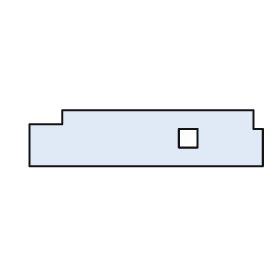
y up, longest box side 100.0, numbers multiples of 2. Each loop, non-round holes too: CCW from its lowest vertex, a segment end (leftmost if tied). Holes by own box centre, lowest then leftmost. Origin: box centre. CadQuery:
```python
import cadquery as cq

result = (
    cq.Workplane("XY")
    .moveTo(-50.0, -12.0)
    .lineTo(50.0, -12.0)
    .lineTo(50.0, 4.0)
    .lineTo(46.0, 4.0)
    .lineTo(46.0, 12.0)
    .lineTo(-36.0, 12.0)
    .lineTo(-36.0, 6.0)
    .lineTo(-50.0, 6.0)
    .close()
    .moveTo(14.0, -4.0)
    .lineTo(22.0, -4.0)
    .lineTo(22.0, 4.0)
    .lineTo(14.0, 4.0)
    .close()
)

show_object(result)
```